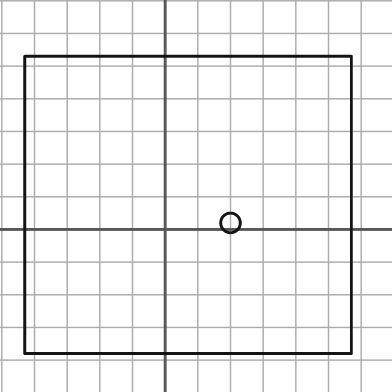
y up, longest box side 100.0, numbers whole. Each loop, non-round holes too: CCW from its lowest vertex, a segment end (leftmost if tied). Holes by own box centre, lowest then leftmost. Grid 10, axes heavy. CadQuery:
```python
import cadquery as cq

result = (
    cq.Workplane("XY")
    .moveTo(-43.0, -38.0)
    .lineTo(57.0, -38.0)
    .lineTo(57.0, 53.0)
    .lineTo(-43.0, 53.0)
    .close()
    .moveTo(20.0, 2.0)
    .circle(3.0)
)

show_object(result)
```